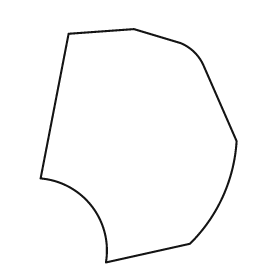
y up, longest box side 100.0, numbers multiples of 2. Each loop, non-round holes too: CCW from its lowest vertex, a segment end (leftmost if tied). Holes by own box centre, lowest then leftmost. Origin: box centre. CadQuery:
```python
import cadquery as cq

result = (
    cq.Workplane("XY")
    .moveTo(-14.0, -50.0)
    .lineTo(22.0, -42.0)
    .threePointArc((36.0, -22.0), (42.0, 2.0))
    .lineTo(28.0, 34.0)
    .threePointArc((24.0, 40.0), (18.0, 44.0))
    .lineTo(-2.0, 50.0)
    .lineTo(-30.0, 48.0)
    .lineTo(-42.0, -14.0)
    .threePointArc((-20.0, -26.0), (-14.0, -50.0))
    .close()
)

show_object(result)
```